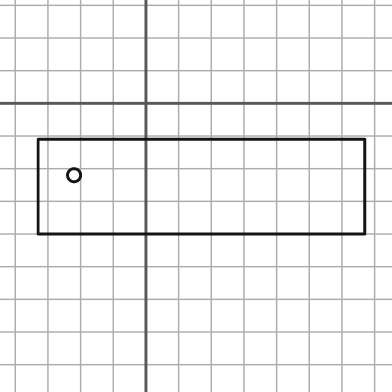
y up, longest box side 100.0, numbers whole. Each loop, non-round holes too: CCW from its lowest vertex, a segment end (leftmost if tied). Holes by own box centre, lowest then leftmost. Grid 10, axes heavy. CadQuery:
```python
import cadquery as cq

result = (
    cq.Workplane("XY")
    .moveTo(-33.0, -40.0)
    .lineTo(67.0, -40.0)
    .lineTo(67.0, -11.0)
    .lineTo(-33.0, -11.0)
    .close()
    .moveTo(-22.0, -22.0)
    .circle(2.0)
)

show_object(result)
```